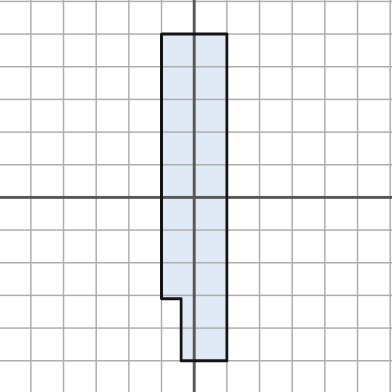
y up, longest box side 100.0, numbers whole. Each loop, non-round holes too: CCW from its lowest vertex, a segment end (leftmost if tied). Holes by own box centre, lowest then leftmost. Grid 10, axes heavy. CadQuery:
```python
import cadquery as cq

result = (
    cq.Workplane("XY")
    .moveTo(-4.0, -50.0)
    .lineTo(10.0, -50.0)
    .lineTo(10.0, 50.0)
    .lineTo(-10.0, 50.0)
    .lineTo(-10.0, -31.0)
    .lineTo(-4.0, -31.0)
    .close()
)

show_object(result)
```